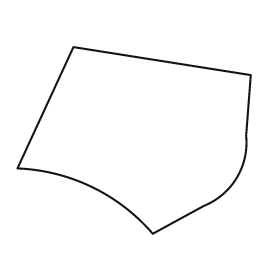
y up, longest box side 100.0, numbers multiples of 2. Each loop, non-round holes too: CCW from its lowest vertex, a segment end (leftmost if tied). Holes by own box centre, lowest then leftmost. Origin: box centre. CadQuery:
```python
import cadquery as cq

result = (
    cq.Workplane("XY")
    .moveTo(8.0, -40.0)
    .lineTo(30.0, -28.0)
    .threePointArc((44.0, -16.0), (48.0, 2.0))
    .lineTo(50.0, 28.0)
    .lineTo(-26.0, 40.0)
    .lineTo(-50.0, -12.0)
    .threePointArc((-18.0, -20.0), (8.0, -40.0))
    .close()
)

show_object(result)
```